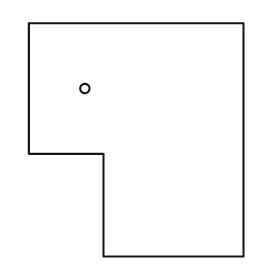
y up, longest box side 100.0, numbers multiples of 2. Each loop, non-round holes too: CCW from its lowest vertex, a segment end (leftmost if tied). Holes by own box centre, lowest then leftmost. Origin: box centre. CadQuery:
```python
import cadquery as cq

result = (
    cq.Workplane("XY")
    .moveTo(-14.0, -50.0)
    .lineTo(46.0, -50.0)
    .lineTo(46.0, 50.0)
    .lineTo(-46.0, 50.0)
    .lineTo(-46.0, -6.0)
    .lineTo(-14.0, -6.0)
    .close()
    .moveTo(-22.0, 22.0)
    .circle(2.0)
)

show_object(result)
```